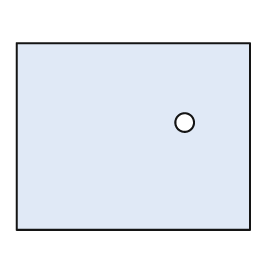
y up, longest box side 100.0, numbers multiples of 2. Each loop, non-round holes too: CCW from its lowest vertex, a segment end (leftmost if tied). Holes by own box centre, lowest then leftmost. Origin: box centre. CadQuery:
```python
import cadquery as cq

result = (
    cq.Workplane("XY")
    .moveTo(-50.0, -40.0)
    .lineTo(50.0, -40.0)
    .lineTo(50.0, 40.0)
    .lineTo(-50.0, 40.0)
    .close()
    .moveTo(22.0, 6.0)
    .circle(4.0)
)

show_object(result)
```